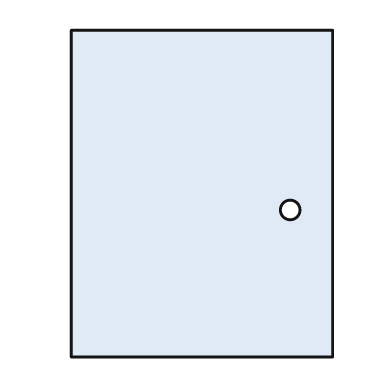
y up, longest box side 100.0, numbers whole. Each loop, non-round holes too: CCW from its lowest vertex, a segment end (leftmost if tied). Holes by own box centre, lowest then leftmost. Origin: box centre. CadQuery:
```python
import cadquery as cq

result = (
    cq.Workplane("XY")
    .moveTo(-40.0, -50.0)
    .lineTo(40.0, -50.0)
    .lineTo(40.0, 50.0)
    .lineTo(-40.0, 50.0)
    .close()
    .moveTo(27.0, -5.0)
    .circle(3.0)
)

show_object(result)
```